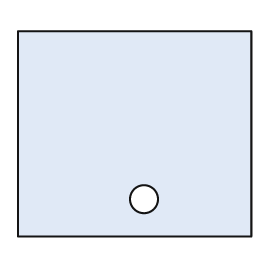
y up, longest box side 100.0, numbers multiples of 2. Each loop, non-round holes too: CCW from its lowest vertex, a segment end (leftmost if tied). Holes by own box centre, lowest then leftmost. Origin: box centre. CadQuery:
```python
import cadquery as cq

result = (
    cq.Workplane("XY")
    .moveTo(-50.0, -44.0)
    .lineTo(50.0, -44.0)
    .lineTo(50.0, 44.0)
    .lineTo(-50.0, 44.0)
    .close()
    .moveTo(4.0, -28.0)
    .circle(6.0)
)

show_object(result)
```